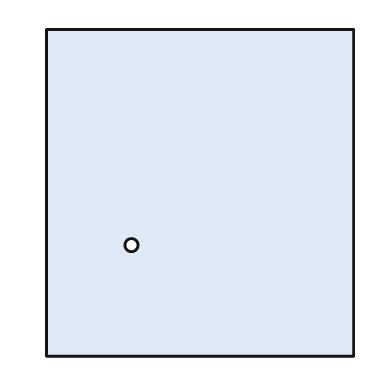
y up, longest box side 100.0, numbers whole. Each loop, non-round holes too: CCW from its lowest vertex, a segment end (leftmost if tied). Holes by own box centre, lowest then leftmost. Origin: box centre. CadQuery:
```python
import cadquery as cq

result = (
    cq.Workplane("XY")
    .moveTo(-47.0, -50.0)
    .lineTo(47.0, -50.0)
    .lineTo(47.0, 50.0)
    .lineTo(-47.0, 50.0)
    .close()
    .moveTo(-21.0, -16.0)
    .circle(2.0)
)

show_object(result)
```